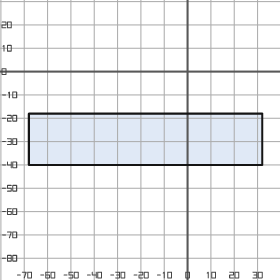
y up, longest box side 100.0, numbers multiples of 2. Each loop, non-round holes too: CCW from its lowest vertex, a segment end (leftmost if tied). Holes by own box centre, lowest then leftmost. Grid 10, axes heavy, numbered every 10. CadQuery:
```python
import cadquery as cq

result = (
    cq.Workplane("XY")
    .moveTo(-68.0, -40.0)
    .lineTo(32.0, -40.0)
    .lineTo(32.0, -18.0)
    .lineTo(-68.0, -18.0)
    .close()
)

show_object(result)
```